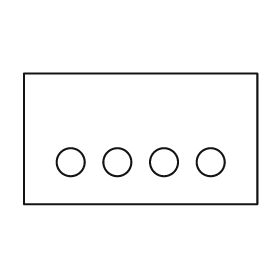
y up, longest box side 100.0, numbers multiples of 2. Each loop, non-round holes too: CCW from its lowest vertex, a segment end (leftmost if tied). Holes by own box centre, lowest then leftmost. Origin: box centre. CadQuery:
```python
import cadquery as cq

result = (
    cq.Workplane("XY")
    .moveTo(-50.0, -28.0)
    .lineTo(50.0, -28.0)
    .lineTo(50.0, 28.0)
    .lineTo(-50.0, 28.0)
    .close()
    .moveTo(-30.0, -10.0)
    .circle(6.0)
    .moveTo(-10.0, -10.0)
    .circle(6.0)
    .moveTo(10.0, -10.0)
    .circle(6.0)
    .moveTo(30.0, -10.0)
    .circle(6.0)
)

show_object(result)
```